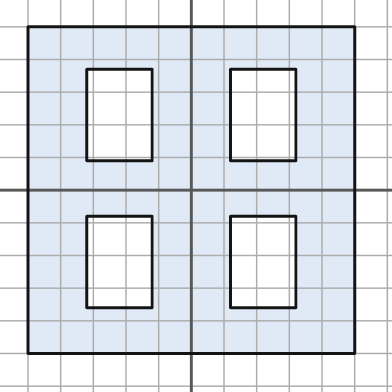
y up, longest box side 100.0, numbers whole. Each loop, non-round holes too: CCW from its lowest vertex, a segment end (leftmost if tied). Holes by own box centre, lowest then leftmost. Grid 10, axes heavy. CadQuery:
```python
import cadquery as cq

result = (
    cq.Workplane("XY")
    .moveTo(-50.0, -50.0)
    .lineTo(50.0, -50.0)
    .lineTo(50.0, 50.0)
    .lineTo(-50.0, 50.0)
    .close()
    .moveTo(-32.0, -36.0)
    .lineTo(-12.0, -36.0)
    .lineTo(-12.0, -8.0)
    .lineTo(-32.0, -8.0)
    .close()
    .moveTo(12.0, -36.0)
    .lineTo(32.0, -36.0)
    .lineTo(32.0, -8.0)
    .lineTo(12.0, -8.0)
    .close()
    .moveTo(-32.0, 9.0)
    .lineTo(-12.0, 9.0)
    .lineTo(-12.0, 37.0)
    .lineTo(-32.0, 37.0)
    .close()
    .moveTo(12.0, 9.0)
    .lineTo(32.0, 9.0)
    .lineTo(32.0, 37.0)
    .lineTo(12.0, 37.0)
    .close()
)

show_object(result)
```